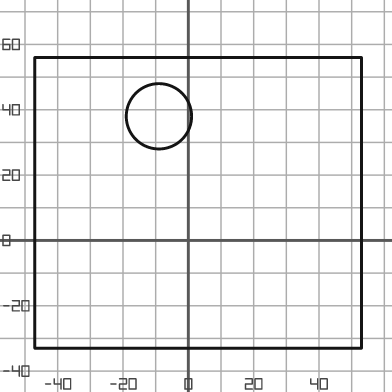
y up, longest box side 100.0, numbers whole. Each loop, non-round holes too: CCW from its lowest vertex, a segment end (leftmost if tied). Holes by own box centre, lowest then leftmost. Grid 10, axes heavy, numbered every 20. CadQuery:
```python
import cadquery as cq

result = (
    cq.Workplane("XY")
    .moveTo(-47.0, -33.0)
    .lineTo(53.0, -33.0)
    .lineTo(53.0, 56.0)
    .lineTo(-47.0, 56.0)
    .close()
    .moveTo(-9.0, 38.0)
    .circle(10.0)
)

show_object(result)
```